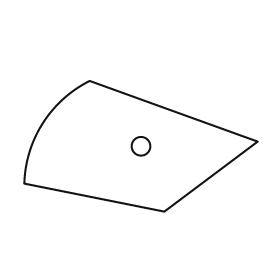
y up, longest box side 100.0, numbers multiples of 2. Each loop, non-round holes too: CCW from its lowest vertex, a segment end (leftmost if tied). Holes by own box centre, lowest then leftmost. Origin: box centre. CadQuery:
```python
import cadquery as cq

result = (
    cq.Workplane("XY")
    .moveTo(10.0, -28.0)
    .lineTo(50.0, 2.0)
    .lineTo(-22.0, 28.0)
    .threePointArc((-42.0, 10.0), (-50.0, -16.0))
    .close()
    .moveTo(0.0, 0.0)
    .circle(4.0)
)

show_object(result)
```